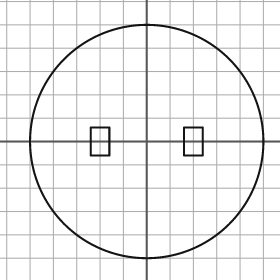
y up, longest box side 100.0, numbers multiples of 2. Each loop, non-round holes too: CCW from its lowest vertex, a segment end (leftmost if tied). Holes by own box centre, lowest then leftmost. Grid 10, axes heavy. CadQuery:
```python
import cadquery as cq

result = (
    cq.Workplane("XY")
    .moveTo(0.0, 0.0)
    .circle(50.0)
    .moveTo(-24.0, -6.0)
    .lineTo(-16.0, -6.0)
    .lineTo(-16.0, 6.0)
    .lineTo(-24.0, 6.0)
    .close()
    .moveTo(16.0, -6.0)
    .lineTo(24.0, -6.0)
    .lineTo(24.0, 6.0)
    .lineTo(16.0, 6.0)
    .close()
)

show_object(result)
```